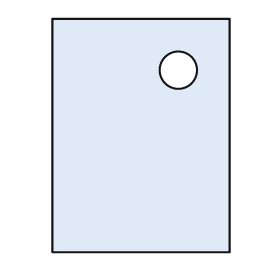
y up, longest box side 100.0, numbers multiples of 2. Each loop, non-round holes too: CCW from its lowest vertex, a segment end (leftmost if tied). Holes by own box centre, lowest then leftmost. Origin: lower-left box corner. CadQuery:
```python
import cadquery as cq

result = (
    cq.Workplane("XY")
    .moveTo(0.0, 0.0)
    .lineTo(76.0, 0.0)
    .lineTo(76.0, 100.0)
    .lineTo(0.0, 100.0)
    .close()
    .moveTo(54.0, 78.0)
    .circle(8.0)
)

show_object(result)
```